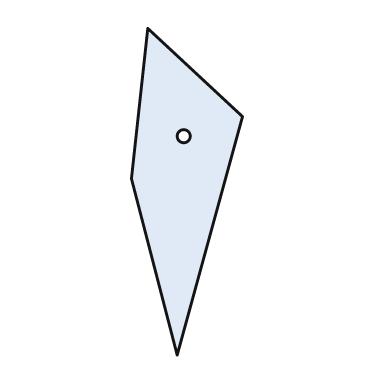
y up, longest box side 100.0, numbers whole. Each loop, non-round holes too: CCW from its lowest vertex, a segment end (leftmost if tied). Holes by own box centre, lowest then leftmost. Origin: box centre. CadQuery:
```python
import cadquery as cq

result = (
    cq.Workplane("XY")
    .moveTo(-3.0, -50.0)
    .lineTo(17.0, 23.0)
    .lineTo(-12.0, 50.0)
    .lineTo(-17.0, 4.0)
    .close()
    .moveTo(-1.0, 17.0)
    .circle(2.0)
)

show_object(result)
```